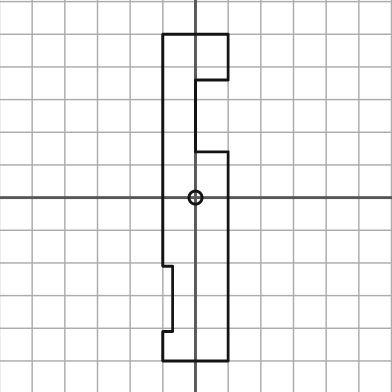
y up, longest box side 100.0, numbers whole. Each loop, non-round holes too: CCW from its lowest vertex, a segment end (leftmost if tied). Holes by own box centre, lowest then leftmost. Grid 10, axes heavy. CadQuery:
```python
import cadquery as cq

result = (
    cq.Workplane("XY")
    .moveTo(-10.0, -50.0)
    .lineTo(10.0, -50.0)
    .lineTo(10.0, 14.0)
    .lineTo(0.0, 14.0)
    .lineTo(0.0, 36.0)
    .lineTo(10.0, 36.0)
    .lineTo(10.0, 50.0)
    .lineTo(-10.0, 50.0)
    .lineTo(-10.0, -21.0)
    .lineTo(-7.0, -21.0)
    .lineTo(-7.0, -41.0)
    .lineTo(-10.0, -41.0)
    .close()
    .moveTo(0.0, 0.0)
    .circle(2.0)
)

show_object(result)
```